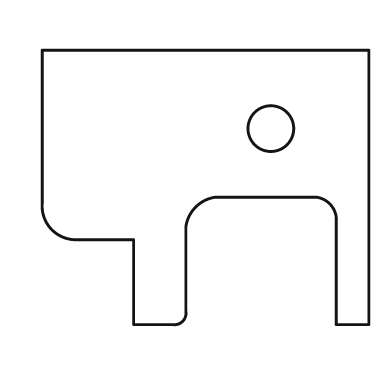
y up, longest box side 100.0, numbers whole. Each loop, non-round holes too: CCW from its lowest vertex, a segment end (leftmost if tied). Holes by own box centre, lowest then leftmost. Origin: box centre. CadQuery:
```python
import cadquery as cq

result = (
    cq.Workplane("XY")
    .moveTo(-22.0, -42.0)
    .lineTo(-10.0, -42.0)
    .threePointArc((-7.0, -41.0), (-6.0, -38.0))
    .lineTo(-6.0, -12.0)
    .threePointArc((-3.0, -6.0), (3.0, -3.0))
    .lineTo(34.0, -3.0)
    .threePointArc((38.0, -5.0), (40.0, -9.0))
    .lineTo(40.0, -42.0)
    .lineTo(50.0, -42.0)
    .lineTo(50.0, 42.0)
    .lineTo(-50.0, 42.0)
    .lineTo(-50.0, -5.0)
    .threePointArc((-47.0, -13.0), (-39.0, -16.0))
    .lineTo(-22.0, -16.0)
    .close()
    .moveTo(20.0, 18.0)
    .circle(7.0)
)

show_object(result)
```